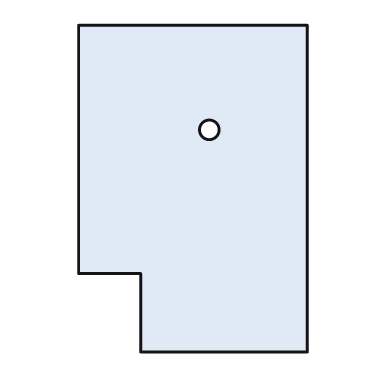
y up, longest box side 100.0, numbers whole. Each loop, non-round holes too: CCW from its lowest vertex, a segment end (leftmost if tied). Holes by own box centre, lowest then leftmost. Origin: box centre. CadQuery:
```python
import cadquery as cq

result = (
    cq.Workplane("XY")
    .moveTo(-16.0, -50.0)
    .lineTo(35.0, -50.0)
    .lineTo(35.0, 50.0)
    .lineTo(-35.0, 50.0)
    .lineTo(-35.0, -26.0)
    .lineTo(-16.0, -26.0)
    .close()
    .moveTo(5.0, 18.0)
    .circle(3.0)
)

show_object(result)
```